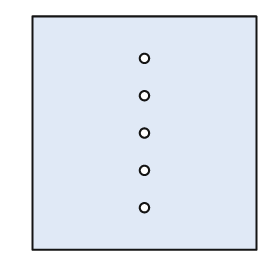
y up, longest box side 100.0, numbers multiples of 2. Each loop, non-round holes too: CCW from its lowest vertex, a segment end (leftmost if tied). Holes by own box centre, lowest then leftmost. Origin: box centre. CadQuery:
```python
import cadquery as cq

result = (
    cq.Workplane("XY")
    .moveTo(-48.0, -50.0)
    .lineTo(48.0, -50.0)
    .lineTo(48.0, 50.0)
    .lineTo(-48.0, 50.0)
    .close()
    .moveTo(0.0, -32.0)
    .circle(2.0)
    .moveTo(0.0, -16.0)
    .circle(2.0)
    .moveTo(0.0, 0.0)
    .circle(2.0)
    .moveTo(0.0, 16.0)
    .circle(2.0)
    .moveTo(0.0, 32.0)
    .circle(2.0)
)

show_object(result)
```